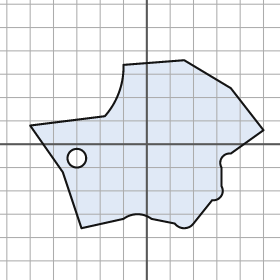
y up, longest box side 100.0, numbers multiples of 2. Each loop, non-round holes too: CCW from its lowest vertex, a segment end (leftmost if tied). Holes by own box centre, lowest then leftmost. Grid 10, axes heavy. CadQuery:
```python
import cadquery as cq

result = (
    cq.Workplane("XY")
    .moveTo(-28.0, -36.0)
    .lineTo(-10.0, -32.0)
    .threePointArc((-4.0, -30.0), (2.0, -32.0))
    .lineTo(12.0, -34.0)
    .threePointArc((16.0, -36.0), (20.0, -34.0))
    .lineTo(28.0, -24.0)
    .threePointArc((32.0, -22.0), (32.0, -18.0))
    .lineTo(32.0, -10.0)
    .threePointArc((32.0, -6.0), (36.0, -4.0))
    .lineTo(50.0, 6.0)
    .lineTo(36.0, 24.0)
    .lineTo(16.0, 36.0)
    .lineTo(-10.0, 34.0)
    .threePointArc((-12.0, 22.0), (-18.0, 12.0))
    .lineTo(-50.0, 8.0)
    .lineTo(-36.0, -12.0)
    .close()
    .moveTo(-30.0, -6.0)
    .circle(4.0)
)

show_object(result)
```